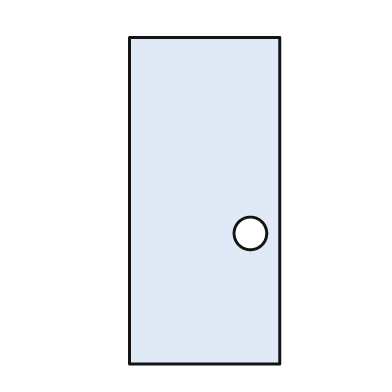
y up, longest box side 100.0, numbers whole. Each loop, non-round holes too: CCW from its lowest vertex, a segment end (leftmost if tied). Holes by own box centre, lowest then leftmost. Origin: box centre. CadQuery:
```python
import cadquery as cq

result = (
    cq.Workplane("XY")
    .moveTo(-23.0, -50.0)
    .lineTo(23.0, -50.0)
    .lineTo(23.0, 50.0)
    .lineTo(-23.0, 50.0)
    .close()
    .moveTo(14.0, -10.0)
    .circle(5.0)
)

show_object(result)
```